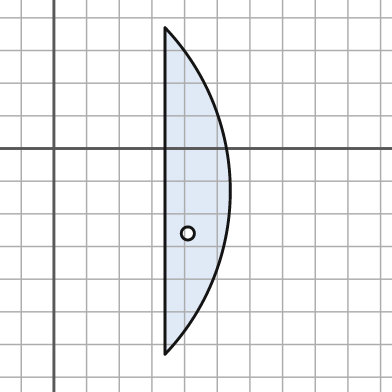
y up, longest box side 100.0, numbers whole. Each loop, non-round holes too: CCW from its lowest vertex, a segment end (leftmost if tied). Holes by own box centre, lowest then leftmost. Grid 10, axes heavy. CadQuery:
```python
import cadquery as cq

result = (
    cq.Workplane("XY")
    .moveTo(34.0, -63.0)
    .threePointArc((54.0, -13.0), (34.0, 37.0))
    .close()
    .moveTo(41.0, -26.0)
    .circle(2.0)
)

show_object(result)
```